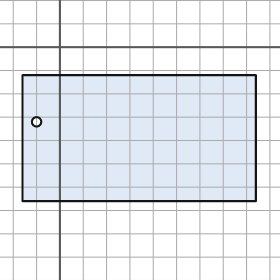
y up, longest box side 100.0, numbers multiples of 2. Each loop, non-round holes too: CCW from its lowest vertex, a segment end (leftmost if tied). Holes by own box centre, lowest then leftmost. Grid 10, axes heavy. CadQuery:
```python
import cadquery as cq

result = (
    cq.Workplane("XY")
    .moveTo(-16.0, -66.0)
    .lineTo(84.0, -66.0)
    .lineTo(84.0, -12.0)
    .lineTo(-16.0, -12.0)
    .close()
    .moveTo(-10.0, -32.0)
    .circle(2.0)
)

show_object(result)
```